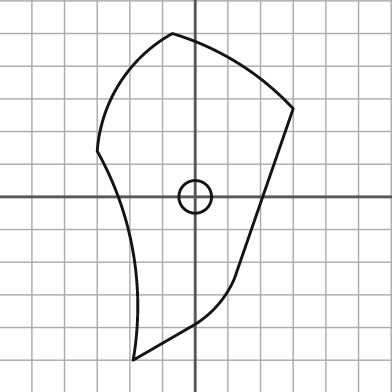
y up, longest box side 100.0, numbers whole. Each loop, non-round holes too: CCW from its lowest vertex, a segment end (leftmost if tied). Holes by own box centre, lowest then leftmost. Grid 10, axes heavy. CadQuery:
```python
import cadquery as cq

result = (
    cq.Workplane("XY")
    .moveTo(-19.0, -50.0)
    .lineTo(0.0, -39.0)
    .threePointArc((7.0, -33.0), (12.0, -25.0))
    .lineTo(30.0, 27.0)
    .threePointArc((13.0, 41.0), (-7.0, 50.0))
    .threePointArc((-23.0, 35.0), (-30.0, 14.0))
    .threePointArc((-19.0, -17.0), (-19.0, -50.0))
    .close()
    .moveTo(0.0, 0.0)
    .circle(5.0)
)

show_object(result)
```